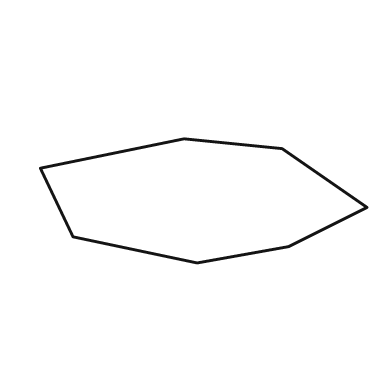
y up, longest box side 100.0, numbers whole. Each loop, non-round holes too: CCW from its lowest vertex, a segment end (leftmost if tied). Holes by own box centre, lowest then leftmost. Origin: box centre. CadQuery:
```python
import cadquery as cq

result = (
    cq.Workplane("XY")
    .moveTo(-2.0, -19.0)
    .lineTo(26.0, -14.0)
    .lineTo(50.0, -2.0)
    .lineTo(24.0, 16.0)
    .lineTo(-6.0, 19.0)
    .lineTo(-50.0, 10.0)
    .lineTo(-40.0, -11.0)
    .close()
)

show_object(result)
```